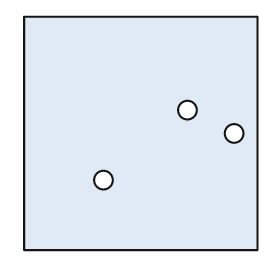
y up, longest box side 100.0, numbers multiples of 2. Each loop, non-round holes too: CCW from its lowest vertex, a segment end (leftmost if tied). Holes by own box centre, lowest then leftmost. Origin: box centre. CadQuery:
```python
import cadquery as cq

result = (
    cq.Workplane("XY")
    .moveTo(-50.0, -50.0)
    .lineTo(50.0, -50.0)
    .lineTo(50.0, 50.0)
    .lineTo(-50.0, 50.0)
    .close()
    .moveTo(-16.0, -20.0)
    .circle(4.0)
    .moveTo(40.0, 0.0)
    .circle(4.0)
    .moveTo(20.0, 10.0)
    .circle(4.0)
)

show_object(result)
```